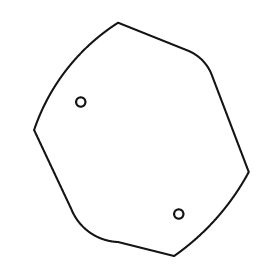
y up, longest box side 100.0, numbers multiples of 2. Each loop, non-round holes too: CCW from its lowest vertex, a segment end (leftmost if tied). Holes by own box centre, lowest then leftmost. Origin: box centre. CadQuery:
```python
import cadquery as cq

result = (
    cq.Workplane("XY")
    .moveTo(14.0, -50.0)
    .threePointArc((32.0, -34.0), (46.0, -14.0))
    .lineTo(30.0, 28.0)
    .threePointArc((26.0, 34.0), (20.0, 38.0))
    .lineTo(-10.0, 50.0)
    .threePointArc((-32.0, 30.0), (-46.0, 4.0))
    .lineTo(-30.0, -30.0)
    .threePointArc((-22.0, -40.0), (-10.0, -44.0))
    .close()
    .moveTo(16.0, -32.0)
    .circle(2.0)
    .moveTo(-26.0, 16.0)
    .circle(2.0)
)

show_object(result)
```